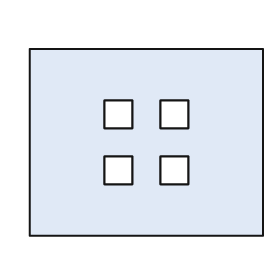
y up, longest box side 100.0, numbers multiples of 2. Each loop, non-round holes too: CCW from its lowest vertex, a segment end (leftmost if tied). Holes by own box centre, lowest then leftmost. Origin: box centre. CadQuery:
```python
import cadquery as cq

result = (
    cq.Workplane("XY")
    .moveTo(-50.0, -40.0)
    .lineTo(50.0, -40.0)
    .lineTo(50.0, 40.0)
    .lineTo(-50.0, 40.0)
    .close()
    .moveTo(-18.0, -18.0)
    .lineTo(-6.0, -18.0)
    .lineTo(-6.0, -6.0)
    .lineTo(-18.0, -6.0)
    .close()
    .moveTo(6.0, -18.0)
    .lineTo(18.0, -18.0)
    .lineTo(18.0, -6.0)
    .lineTo(6.0, -6.0)
    .close()
    .moveTo(-18.0, 6.0)
    .lineTo(-6.0, 6.0)
    .lineTo(-6.0, 18.0)
    .lineTo(-18.0, 18.0)
    .close()
    .moveTo(6.0, 6.0)
    .lineTo(18.0, 6.0)
    .lineTo(18.0, 18.0)
    .lineTo(6.0, 18.0)
    .close()
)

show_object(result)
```